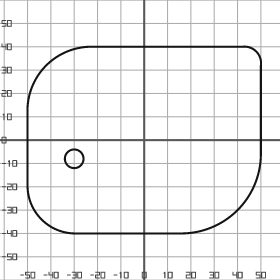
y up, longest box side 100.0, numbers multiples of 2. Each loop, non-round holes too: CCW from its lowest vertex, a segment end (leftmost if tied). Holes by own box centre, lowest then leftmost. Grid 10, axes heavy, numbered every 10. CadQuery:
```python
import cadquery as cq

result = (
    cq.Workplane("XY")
    .moveTo(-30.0, -40.0)
    .lineTo(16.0, -40.0)
    .threePointArc((40.0, -30.0), (50.0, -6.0))
    .lineTo(50.0, 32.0)
    .threePointArc((48.0, 38.0), (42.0, 40.0))
    .lineTo(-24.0, 40.0)
    .threePointArc((-42.0, 32.0), (-50.0, 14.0))
    .lineTo(-50.0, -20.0)
    .threePointArc((-44.0, -34.0), (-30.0, -40.0))
    .close()
    .moveTo(-30.0, -8.0)
    .circle(4.0)
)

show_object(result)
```